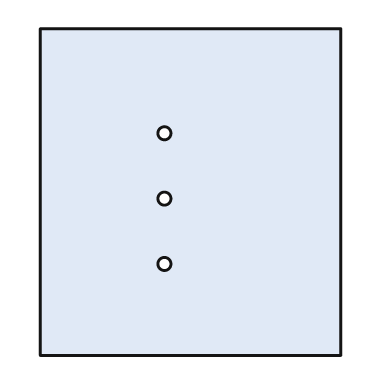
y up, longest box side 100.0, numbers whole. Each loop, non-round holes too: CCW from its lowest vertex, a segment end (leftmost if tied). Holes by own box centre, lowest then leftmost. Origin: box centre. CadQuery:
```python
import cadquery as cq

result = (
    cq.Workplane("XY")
    .moveTo(-46.0, -50.0)
    .lineTo(46.0, -50.0)
    .lineTo(46.0, 50.0)
    .lineTo(-46.0, 50.0)
    .close()
    .moveTo(-8.0, -22.0)
    .circle(2.0)
    .moveTo(-8.0, -2.0)
    .circle(2.0)
    .moveTo(-8.0, 18.0)
    .circle(2.0)
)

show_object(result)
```